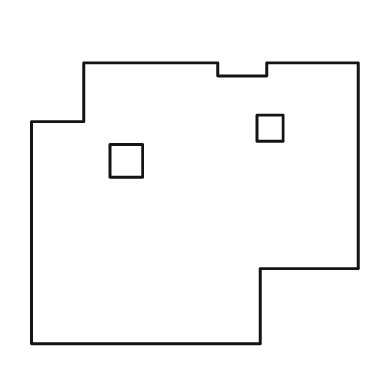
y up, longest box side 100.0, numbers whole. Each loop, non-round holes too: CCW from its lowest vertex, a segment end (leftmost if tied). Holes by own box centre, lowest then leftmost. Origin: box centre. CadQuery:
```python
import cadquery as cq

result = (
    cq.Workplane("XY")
    .moveTo(-50.0, -43.0)
    .lineTo(20.0, -43.0)
    .lineTo(20.0, -20.0)
    .lineTo(50.0, -20.0)
    .lineTo(50.0, 43.0)
    .lineTo(22.0, 43.0)
    .lineTo(22.0, 39.0)
    .lineTo(7.0, 39.0)
    .lineTo(7.0, 43.0)
    .lineTo(-34.0, 43.0)
    .lineTo(-34.0, 25.0)
    .lineTo(-50.0, 25.0)
    .close()
    .moveTo(-26.0, 8.0)
    .lineTo(-16.0, 8.0)
    .lineTo(-16.0, 18.0)
    .lineTo(-26.0, 18.0)
    .close()
    .moveTo(19.0, 19.0)
    .lineTo(27.0, 19.0)
    .lineTo(27.0, 27.0)
    .lineTo(19.0, 27.0)
    .close()
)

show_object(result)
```